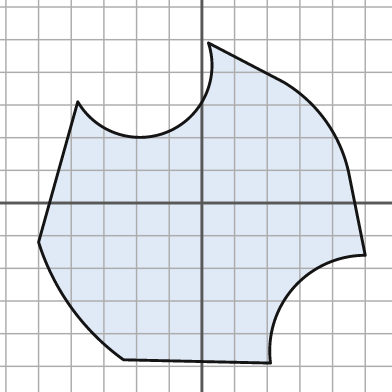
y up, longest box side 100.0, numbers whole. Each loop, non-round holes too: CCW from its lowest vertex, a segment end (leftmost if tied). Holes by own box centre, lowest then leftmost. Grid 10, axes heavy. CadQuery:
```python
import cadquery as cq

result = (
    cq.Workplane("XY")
    .moveTo(21.0, -49.0)
    .threePointArc((28.0, -26.0), (50.0, -16.0))
    .lineTo(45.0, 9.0)
    .threePointArc((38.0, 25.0), (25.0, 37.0))
    .lineTo(2.0, 49.0)
    .threePointArc((-10.0, 22.0), (-38.0, 31.0))
    .lineTo(-50.0, -12.0)
    .threePointArc((-40.0, -32.0), (-24.0, -48.0))
    .close()
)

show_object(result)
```